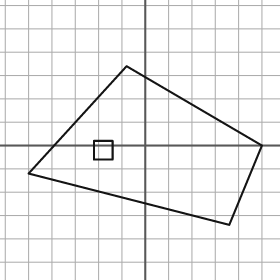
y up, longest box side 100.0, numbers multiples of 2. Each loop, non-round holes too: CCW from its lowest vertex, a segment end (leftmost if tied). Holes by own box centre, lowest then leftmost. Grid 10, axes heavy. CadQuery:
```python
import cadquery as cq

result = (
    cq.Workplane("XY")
    .moveTo(36.0, -34.0)
    .lineTo(50.0, 0.0)
    .lineTo(-8.0, 34.0)
    .lineTo(-50.0, -12.0)
    .close()
    .moveTo(-22.0, -6.0)
    .lineTo(-14.0, -6.0)
    .lineTo(-14.0, 2.0)
    .lineTo(-22.0, 2.0)
    .close()
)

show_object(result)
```